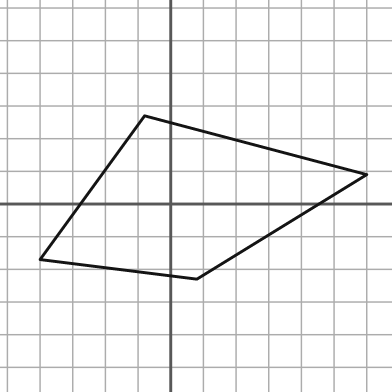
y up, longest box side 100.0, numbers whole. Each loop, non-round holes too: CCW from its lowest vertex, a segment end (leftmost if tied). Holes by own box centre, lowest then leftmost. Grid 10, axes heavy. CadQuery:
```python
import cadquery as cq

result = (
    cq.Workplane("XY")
    .moveTo(8.0, -23.0)
    .lineTo(60.0, 9.0)
    .lineTo(-8.0, 27.0)
    .lineTo(-40.0, -17.0)
    .close()
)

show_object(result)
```